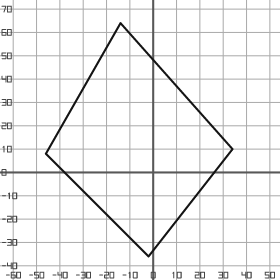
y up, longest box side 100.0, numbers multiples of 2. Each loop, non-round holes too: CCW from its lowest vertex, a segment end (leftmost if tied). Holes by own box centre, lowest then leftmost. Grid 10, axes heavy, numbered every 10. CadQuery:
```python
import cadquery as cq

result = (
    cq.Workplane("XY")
    .moveTo(-2.0, -36.0)
    .lineTo(34.0, 10.0)
    .lineTo(-14.0, 64.0)
    .lineTo(-46.0, 8.0)
    .close()
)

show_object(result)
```